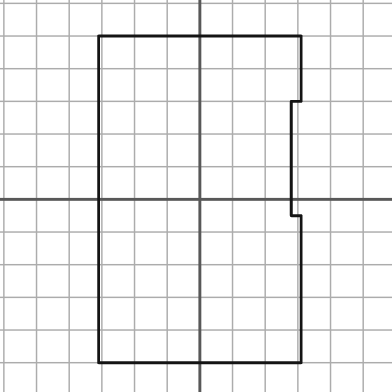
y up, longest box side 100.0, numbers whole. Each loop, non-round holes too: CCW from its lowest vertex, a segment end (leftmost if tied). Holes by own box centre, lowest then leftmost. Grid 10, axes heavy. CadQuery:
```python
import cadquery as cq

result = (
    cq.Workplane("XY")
    .moveTo(-31.0, -50.0)
    .lineTo(31.0, -50.0)
    .lineTo(31.0, -5.0)
    .lineTo(28.0, -5.0)
    .lineTo(28.0, 30.0)
    .lineTo(31.0, 30.0)
    .lineTo(31.0, 50.0)
    .lineTo(-31.0, 50.0)
    .close()
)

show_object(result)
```